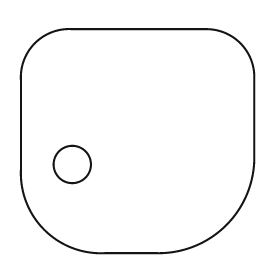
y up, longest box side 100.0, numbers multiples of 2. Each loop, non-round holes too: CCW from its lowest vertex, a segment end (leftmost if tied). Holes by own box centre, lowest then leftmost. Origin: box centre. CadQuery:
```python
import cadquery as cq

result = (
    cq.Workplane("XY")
    .moveTo(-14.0, -48.0)
    .lineTo(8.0, -48.0)
    .threePointArc((38.0, -36.0), (50.0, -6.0))
    .lineTo(50.0, 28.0)
    .threePointArc((44.0, 42.0), (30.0, 48.0))
    .lineTo(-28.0, 48.0)
    .threePointArc((-44.0, 42.0), (-50.0, 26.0))
    .lineTo(-50.0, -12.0)
    .threePointArc((-40.0, -38.0), (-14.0, -48.0))
    .close()
    .moveTo(-28.0, -10.0)
    .circle(8.0)
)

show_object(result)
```